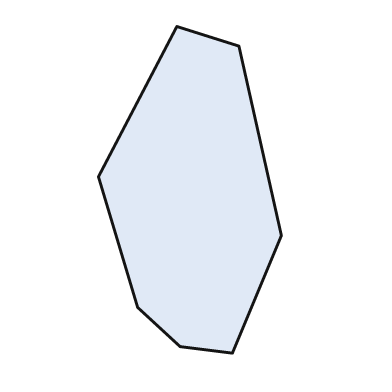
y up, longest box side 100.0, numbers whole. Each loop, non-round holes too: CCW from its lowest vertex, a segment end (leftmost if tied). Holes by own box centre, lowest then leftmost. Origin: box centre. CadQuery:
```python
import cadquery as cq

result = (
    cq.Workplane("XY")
    .moveTo(13.0, -50.0)
    .lineTo(28.0, -14.0)
    .lineTo(15.0, 44.0)
    .lineTo(-4.0, 50.0)
    .lineTo(-28.0, 4.0)
    .lineTo(-16.0, -36.0)
    .lineTo(-3.0, -48.0)
    .close()
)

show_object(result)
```